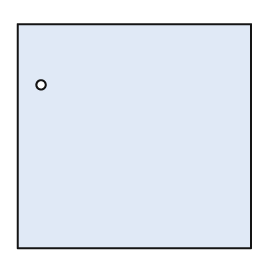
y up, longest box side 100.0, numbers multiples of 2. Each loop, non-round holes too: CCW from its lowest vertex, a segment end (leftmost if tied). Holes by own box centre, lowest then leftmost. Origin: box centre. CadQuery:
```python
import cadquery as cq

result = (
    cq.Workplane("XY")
    .moveTo(-50.0, -48.0)
    .lineTo(50.0, -48.0)
    .lineTo(50.0, 48.0)
    .lineTo(-50.0, 48.0)
    .close()
    .moveTo(-40.0, 22.0)
    .circle(2.0)
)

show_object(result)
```